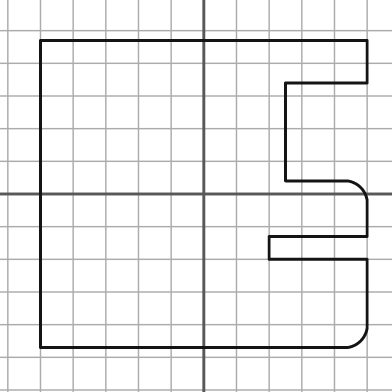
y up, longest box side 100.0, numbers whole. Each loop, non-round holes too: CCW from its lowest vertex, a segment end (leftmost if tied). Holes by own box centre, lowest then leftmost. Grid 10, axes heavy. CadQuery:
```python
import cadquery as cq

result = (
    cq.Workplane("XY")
    .moveTo(-50.0, -47.0)
    .lineTo(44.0, -47.0)
    .threePointArc((48.0, -45.0), (50.0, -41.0))
    .lineTo(50.0, -20.0)
    .lineTo(20.0, -20.0)
    .lineTo(20.0, -13.0)
    .lineTo(50.0, -13.0)
    .lineTo(50.0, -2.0)
    .threePointArc((48.0, 2.0), (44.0, 4.0))
    .lineTo(25.0, 4.0)
    .lineTo(25.0, 34.0)
    .lineTo(50.0, 34.0)
    .lineTo(50.0, 47.0)
    .lineTo(-50.0, 47.0)
    .close()
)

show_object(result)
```